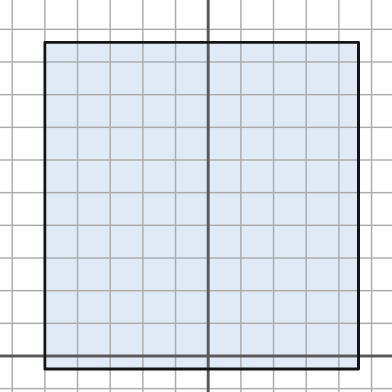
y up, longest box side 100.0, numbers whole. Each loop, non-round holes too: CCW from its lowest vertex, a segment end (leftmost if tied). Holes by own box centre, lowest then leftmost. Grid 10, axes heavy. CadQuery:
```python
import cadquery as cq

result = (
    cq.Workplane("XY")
    .moveTo(-50.0, -4.0)
    .lineTo(46.0, -4.0)
    .lineTo(46.0, 96.0)
    .lineTo(-50.0, 96.0)
    .close()
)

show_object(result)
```